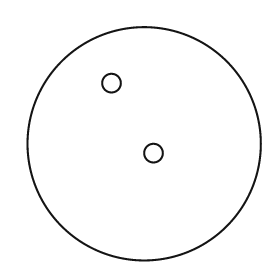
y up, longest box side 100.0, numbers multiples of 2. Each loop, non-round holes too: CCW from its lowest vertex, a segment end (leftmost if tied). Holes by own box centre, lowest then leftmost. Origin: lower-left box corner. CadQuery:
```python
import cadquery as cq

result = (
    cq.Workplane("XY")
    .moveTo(50.0, 50.0)
    .circle(50.0)
    .moveTo(54.0, 46.0)
    .circle(4.0)
    .moveTo(36.0, 76.0)
    .circle(4.0)
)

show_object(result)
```